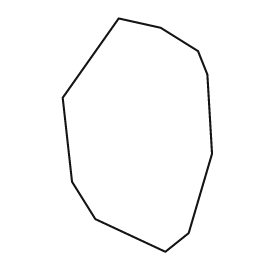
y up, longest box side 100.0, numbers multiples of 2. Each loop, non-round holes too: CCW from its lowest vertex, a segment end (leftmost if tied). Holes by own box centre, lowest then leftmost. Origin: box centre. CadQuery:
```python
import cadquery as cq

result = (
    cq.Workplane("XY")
    .moveTo(12.0, -50.0)
    .lineTo(22.0, -42.0)
    .lineTo(32.0, -8.0)
    .lineTo(30.0, 26.0)
    .lineTo(26.0, 36.0)
    .lineTo(10.0, 46.0)
    .lineTo(-8.0, 50.0)
    .lineTo(-32.0, 16.0)
    .lineTo(-28.0, -20.0)
    .lineTo(-18.0, -36.0)
    .close()
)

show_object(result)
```